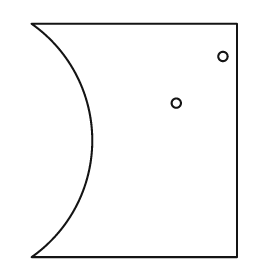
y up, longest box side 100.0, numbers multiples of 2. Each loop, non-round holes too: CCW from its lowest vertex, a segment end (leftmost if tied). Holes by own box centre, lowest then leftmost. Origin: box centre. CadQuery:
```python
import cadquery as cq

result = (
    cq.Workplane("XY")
    .moveTo(-44.0, -50.0)
    .lineTo(44.0, -50.0)
    .lineTo(44.0, 50.0)
    .lineTo(-44.0, 50.0)
    .threePointArc((-18.0, 0.0), (-44.0, -50.0))
    .close()
    .moveTo(18.0, 16.0)
    .circle(2.0)
    .moveTo(38.0, 36.0)
    .circle(2.0)
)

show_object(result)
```